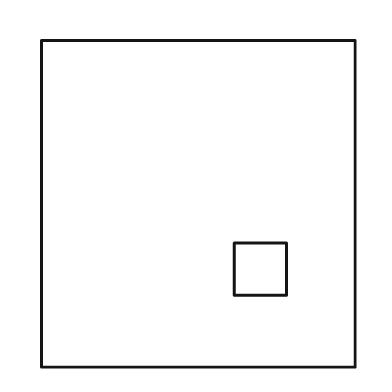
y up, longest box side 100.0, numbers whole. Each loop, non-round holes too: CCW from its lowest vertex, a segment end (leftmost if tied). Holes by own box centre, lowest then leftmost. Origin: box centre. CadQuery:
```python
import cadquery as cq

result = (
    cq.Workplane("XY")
    .moveTo(-48.0, -50.0)
    .lineTo(48.0, -50.0)
    .lineTo(48.0, 50.0)
    .lineTo(-48.0, 50.0)
    .close()
    .moveTo(11.0, -28.0)
    .lineTo(27.0, -28.0)
    .lineTo(27.0, -12.0)
    .lineTo(11.0, -12.0)
    .close()
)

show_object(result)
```